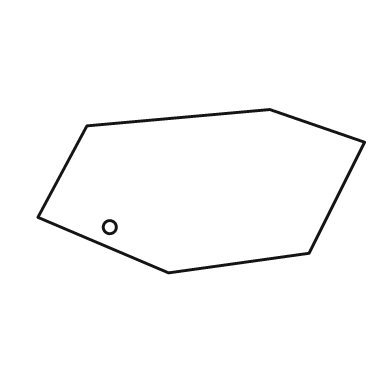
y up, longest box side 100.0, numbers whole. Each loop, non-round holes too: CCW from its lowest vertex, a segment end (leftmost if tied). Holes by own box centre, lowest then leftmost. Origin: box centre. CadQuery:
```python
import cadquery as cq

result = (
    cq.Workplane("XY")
    .moveTo(-10.0, -25.0)
    .lineTo(33.0, -19.0)
    .lineTo(50.0, 15.0)
    .lineTo(21.0, 25.0)
    .lineTo(-35.0, 20.0)
    .lineTo(-50.0, -8.0)
    .close()
    .moveTo(-28.0, -11.0)
    .circle(2.0)
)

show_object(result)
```